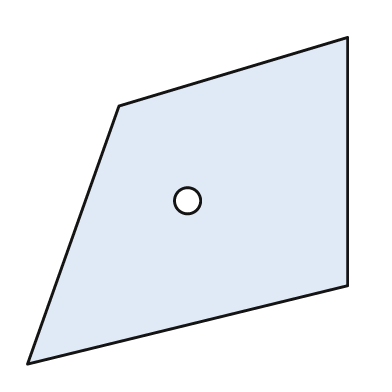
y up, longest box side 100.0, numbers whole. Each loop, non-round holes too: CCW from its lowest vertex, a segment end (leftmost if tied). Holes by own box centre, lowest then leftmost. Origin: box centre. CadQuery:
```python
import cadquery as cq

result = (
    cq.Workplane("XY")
    .moveTo(-49.0, -50.0)
    .lineTo(49.0, -26.0)
    .lineTo(49.0, 50.0)
    .lineTo(-21.0, 29.0)
    .close()
    .moveTo(0.0, 0.0)
    .circle(4.0)
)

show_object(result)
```